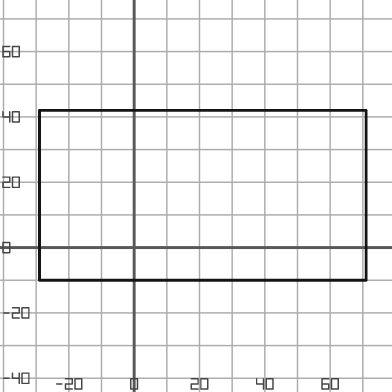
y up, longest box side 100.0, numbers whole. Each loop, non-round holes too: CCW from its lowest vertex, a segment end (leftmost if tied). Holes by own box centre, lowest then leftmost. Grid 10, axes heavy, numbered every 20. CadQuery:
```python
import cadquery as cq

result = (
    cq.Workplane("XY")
    .moveTo(-29.0, -10.0)
    .lineTo(71.0, -10.0)
    .lineTo(71.0, 42.0)
    .lineTo(-29.0, 42.0)
    .close()
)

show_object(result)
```